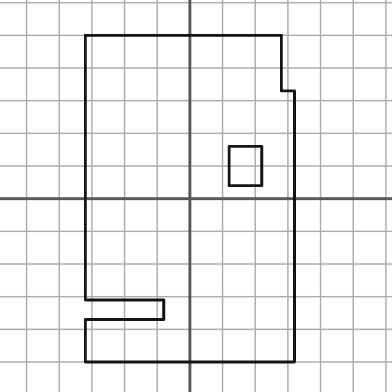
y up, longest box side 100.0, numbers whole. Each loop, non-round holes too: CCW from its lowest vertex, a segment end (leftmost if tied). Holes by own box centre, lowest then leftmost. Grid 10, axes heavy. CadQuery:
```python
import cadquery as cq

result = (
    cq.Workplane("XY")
    .moveTo(-32.0, -50.0)
    .lineTo(32.0, -50.0)
    .lineTo(32.0, 33.0)
    .lineTo(28.0, 33.0)
    .lineTo(28.0, 50.0)
    .lineTo(-32.0, 50.0)
    .lineTo(-32.0, -31.0)
    .lineTo(-8.0, -31.0)
    .lineTo(-8.0, -37.0)
    .lineTo(-32.0, -37.0)
    .close()
    .moveTo(12.0, 4.0)
    .lineTo(22.0, 4.0)
    .lineTo(22.0, 16.0)
    .lineTo(12.0, 16.0)
    .close()
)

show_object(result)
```